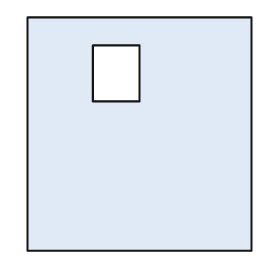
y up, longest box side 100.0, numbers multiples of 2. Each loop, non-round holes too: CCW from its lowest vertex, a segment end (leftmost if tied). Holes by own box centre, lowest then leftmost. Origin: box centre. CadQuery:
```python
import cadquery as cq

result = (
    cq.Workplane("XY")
    .moveTo(-48.0, -50.0)
    .lineTo(48.0, -50.0)
    .lineTo(48.0, 50.0)
    .lineTo(-48.0, 50.0)
    .close()
    .moveTo(-20.0, 14.0)
    .lineTo(0.0, 14.0)
    .lineTo(0.0, 38.0)
    .lineTo(-20.0, 38.0)
    .close()
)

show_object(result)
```